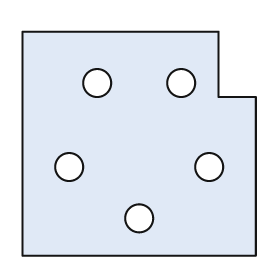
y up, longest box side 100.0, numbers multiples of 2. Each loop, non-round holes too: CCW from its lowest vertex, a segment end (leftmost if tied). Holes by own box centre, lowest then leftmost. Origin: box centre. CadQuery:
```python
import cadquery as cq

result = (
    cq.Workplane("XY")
    .moveTo(-50.0, -48.0)
    .lineTo(50.0, -48.0)
    .lineTo(50.0, 20.0)
    .lineTo(34.0, 20.0)
    .lineTo(34.0, 48.0)
    .lineTo(-50.0, 48.0)
    .close()
    .moveTo(0.0, -32.0)
    .circle(6.0)
    .moveTo(-30.0, -10.0)
    .circle(6.0)
    .moveTo(30.0, -10.0)
    .circle(6.0)
    .moveTo(-18.0, 26.0)
    .circle(6.0)
    .moveTo(18.0, 26.0)
    .circle(6.0)
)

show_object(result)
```